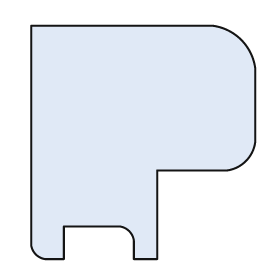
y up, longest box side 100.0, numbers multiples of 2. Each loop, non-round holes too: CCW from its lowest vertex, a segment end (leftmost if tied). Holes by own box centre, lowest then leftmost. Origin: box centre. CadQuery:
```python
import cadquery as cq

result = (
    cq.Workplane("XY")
    .moveTo(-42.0, -50.0)
    .lineTo(-34.0, -50.0)
    .lineTo(-34.0, -36.0)
    .lineTo(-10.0, -36.0)
    .threePointArc((-6.0, -38.0), (-4.0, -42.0))
    .lineTo(-4.0, -50.0)
    .lineTo(6.0, -50.0)
    .lineTo(6.0, -12.0)
    .lineTo(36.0, -12.0)
    .threePointArc((44.0, -8.0), (48.0, 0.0))
    .lineTo(48.0, 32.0)
    .threePointArc((42.0, 44.0), (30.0, 50.0))
    .lineTo(-48.0, 50.0)
    .lineTo(-48.0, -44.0)
    .threePointArc((-46.0, -48.0), (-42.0, -50.0))
    .close()
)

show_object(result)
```